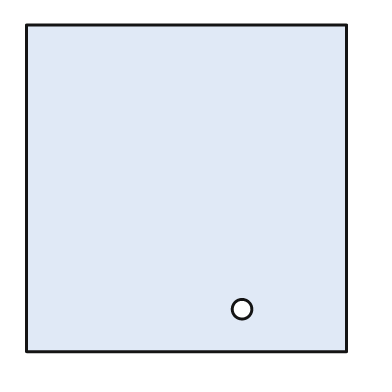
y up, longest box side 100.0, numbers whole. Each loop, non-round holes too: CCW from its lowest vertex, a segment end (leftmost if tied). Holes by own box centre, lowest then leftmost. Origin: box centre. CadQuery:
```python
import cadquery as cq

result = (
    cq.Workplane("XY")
    .moveTo(-49.0, -50.0)
    .lineTo(49.0, -50.0)
    .lineTo(49.0, 50.0)
    .lineTo(-49.0, 50.0)
    .close()
    .moveTo(17.0, -37.0)
    .circle(3.0)
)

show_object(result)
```